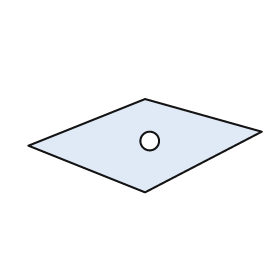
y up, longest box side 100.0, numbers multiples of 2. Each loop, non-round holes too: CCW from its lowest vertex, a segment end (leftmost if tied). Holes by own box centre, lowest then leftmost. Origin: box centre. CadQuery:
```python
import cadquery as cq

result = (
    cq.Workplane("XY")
    .moveTo(0.0, -20.0)
    .lineTo(50.0, 6.0)
    .lineTo(0.0, 20.0)
    .lineTo(-50.0, 0.0)
    .close()
    .moveTo(2.0, 2.0)
    .circle(4.0)
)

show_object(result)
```